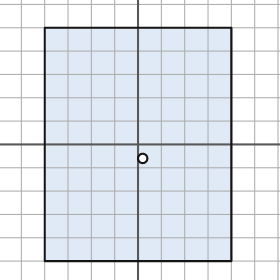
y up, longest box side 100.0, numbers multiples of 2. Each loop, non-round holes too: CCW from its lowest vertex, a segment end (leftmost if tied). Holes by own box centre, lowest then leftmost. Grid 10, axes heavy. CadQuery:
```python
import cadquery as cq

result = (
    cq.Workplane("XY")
    .moveTo(-40.0, -50.0)
    .lineTo(40.0, -50.0)
    .lineTo(40.0, 50.0)
    .lineTo(-40.0, 50.0)
    .close()
    .moveTo(2.0, -6.0)
    .circle(2.0)
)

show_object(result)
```